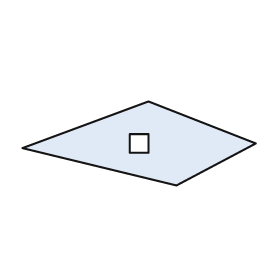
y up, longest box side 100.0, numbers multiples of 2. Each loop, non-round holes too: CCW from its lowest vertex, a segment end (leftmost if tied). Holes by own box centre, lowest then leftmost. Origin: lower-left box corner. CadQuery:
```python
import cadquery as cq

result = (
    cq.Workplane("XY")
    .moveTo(66.0, 0.0)
    .lineTo(100.0, 18.0)
    .lineTo(54.0, 36.0)
    .lineTo(0.0, 16.0)
    .close()
    .moveTo(46.0, 14.0)
    .lineTo(54.0, 14.0)
    .lineTo(54.0, 22.0)
    .lineTo(46.0, 22.0)
    .close()
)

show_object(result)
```